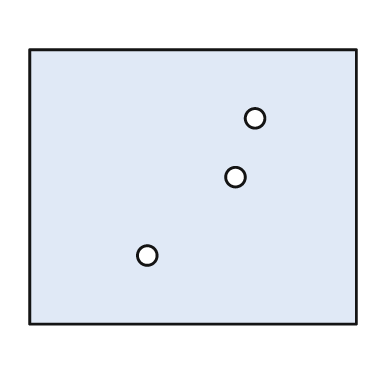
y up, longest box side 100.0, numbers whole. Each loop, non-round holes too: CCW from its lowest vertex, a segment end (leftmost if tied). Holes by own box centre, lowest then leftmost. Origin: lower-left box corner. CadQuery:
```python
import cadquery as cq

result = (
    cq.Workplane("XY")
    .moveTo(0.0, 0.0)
    .lineTo(100.0, 0.0)
    .lineTo(100.0, 84.0)
    .lineTo(0.0, 84.0)
    .close()
    .moveTo(36.0, 21.0)
    .circle(3.0)
    .moveTo(63.0, 45.0)
    .circle(3.0)
    .moveTo(69.0, 63.0)
    .circle(3.0)
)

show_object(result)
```